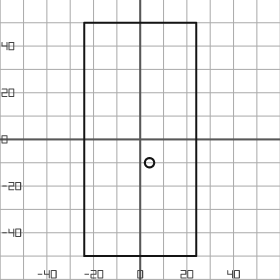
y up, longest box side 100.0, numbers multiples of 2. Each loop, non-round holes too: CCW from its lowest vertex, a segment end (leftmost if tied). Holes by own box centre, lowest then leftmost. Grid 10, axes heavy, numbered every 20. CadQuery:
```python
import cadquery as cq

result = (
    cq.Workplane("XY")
    .moveTo(-24.0, -50.0)
    .lineTo(24.0, -50.0)
    .lineTo(24.0, 50.0)
    .lineTo(-24.0, 50.0)
    .close()
    .moveTo(4.0, -10.0)
    .circle(2.0)
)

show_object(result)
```